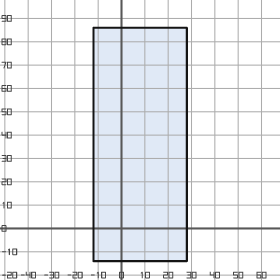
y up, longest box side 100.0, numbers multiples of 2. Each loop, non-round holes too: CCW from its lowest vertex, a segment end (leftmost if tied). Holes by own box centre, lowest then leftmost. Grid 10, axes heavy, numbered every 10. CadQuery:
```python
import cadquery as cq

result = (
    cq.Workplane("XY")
    .moveTo(-12.0, -14.0)
    .lineTo(28.0, -14.0)
    .lineTo(28.0, 86.0)
    .lineTo(-12.0, 86.0)
    .close()
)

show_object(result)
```